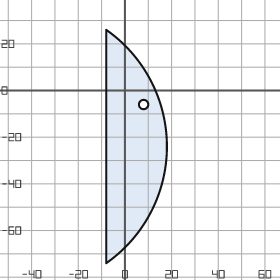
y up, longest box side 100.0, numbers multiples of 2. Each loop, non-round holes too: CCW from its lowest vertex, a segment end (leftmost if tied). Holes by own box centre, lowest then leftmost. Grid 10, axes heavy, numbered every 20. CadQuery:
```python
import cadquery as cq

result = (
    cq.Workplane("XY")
    .moveTo(-8.0, -74.0)
    .threePointArc((18.0, -24.0), (-8.0, 26.0))
    .close()
    .moveTo(8.0, -6.0)
    .circle(2.0)
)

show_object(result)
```